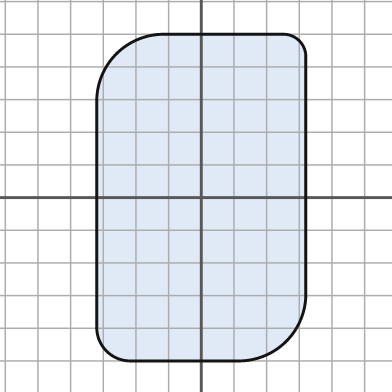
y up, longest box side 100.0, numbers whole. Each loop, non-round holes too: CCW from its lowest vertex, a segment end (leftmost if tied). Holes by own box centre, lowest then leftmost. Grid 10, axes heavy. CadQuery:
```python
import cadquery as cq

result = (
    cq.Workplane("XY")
    .moveTo(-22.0, -50.0)
    .lineTo(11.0, -50.0)
    .threePointArc((26.0, -44.0), (32.0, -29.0))
    .lineTo(32.0, 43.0)
    .threePointArc((30.0, 48.0), (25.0, 50.0))
    .lineTo(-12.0, 50.0)
    .threePointArc((-26.0, 44.0), (-32.0, 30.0))
    .lineTo(-32.0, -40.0)
    .threePointArc((-29.0, -47.0), (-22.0, -50.0))
    .close()
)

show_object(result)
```